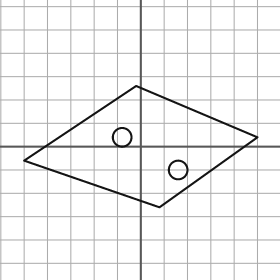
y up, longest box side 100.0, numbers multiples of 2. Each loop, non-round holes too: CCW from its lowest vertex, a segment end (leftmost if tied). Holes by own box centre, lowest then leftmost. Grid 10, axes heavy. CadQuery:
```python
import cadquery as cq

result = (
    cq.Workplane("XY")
    .moveTo(8.0, -26.0)
    .lineTo(50.0, 4.0)
    .lineTo(-2.0, 26.0)
    .lineTo(-50.0, -6.0)
    .close()
    .moveTo(16.0, -10.0)
    .circle(4.0)
    .moveTo(-8.0, 4.0)
    .circle(4.0)
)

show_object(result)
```